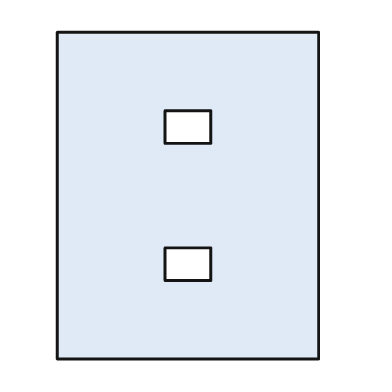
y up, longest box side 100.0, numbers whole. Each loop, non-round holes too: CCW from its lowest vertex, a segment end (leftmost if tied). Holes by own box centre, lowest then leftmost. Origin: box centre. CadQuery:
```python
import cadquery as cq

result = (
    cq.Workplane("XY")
    .moveTo(-40.0, -50.0)
    .lineTo(40.0, -50.0)
    .lineTo(40.0, 50.0)
    .lineTo(-40.0, 50.0)
    .close()
    .moveTo(-7.0, -26.0)
    .lineTo(7.0, -26.0)
    .lineTo(7.0, -16.0)
    .lineTo(-7.0, -16.0)
    .close()
    .moveTo(-7.0, 16.0)
    .lineTo(7.0, 16.0)
    .lineTo(7.0, 26.0)
    .lineTo(-7.0, 26.0)
    .close()
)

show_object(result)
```